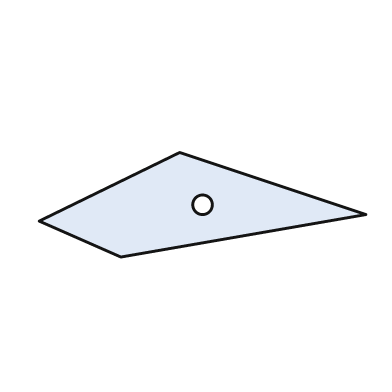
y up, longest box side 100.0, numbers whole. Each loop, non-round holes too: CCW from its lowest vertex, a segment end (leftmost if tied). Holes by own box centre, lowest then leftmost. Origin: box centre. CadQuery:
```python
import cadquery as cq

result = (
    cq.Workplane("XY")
    .moveTo(-25.0, -16.0)
    .lineTo(50.0, -3.0)
    .lineTo(-7.0, 16.0)
    .lineTo(-50.0, -5.0)
    .close()
    .moveTo(0.0, 0.0)
    .circle(3.0)
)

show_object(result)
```